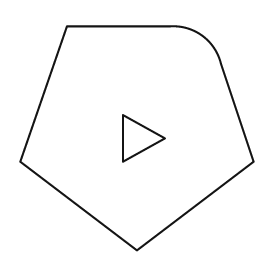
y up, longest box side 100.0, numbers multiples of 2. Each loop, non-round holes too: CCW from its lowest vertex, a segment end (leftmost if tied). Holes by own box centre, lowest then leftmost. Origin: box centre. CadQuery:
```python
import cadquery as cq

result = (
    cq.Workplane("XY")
    .moveTo(0.0, -48.0)
    .lineTo(50.0, -10.0)
    .lineTo(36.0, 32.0)
    .threePointArc((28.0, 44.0), (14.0, 48.0))
    .lineTo(-30.0, 48.0)
    .lineTo(-50.0, -10.0)
    .close()
    .moveTo(-6.0, -10.0)
    .lineTo(12.0, 0.0)
    .lineTo(-6.0, 10.0)
    .close()
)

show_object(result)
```